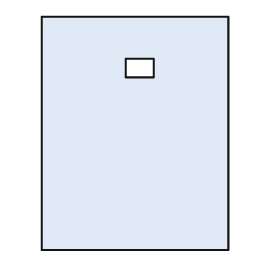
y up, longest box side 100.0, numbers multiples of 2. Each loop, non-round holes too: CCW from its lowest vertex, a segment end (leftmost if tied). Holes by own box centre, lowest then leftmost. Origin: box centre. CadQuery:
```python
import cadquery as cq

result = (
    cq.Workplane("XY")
    .moveTo(-40.0, -50.0)
    .lineTo(40.0, -50.0)
    .lineTo(40.0, 50.0)
    .lineTo(-40.0, 50.0)
    .close()
    .moveTo(-4.0, 24.0)
    .lineTo(8.0, 24.0)
    .lineTo(8.0, 32.0)
    .lineTo(-4.0, 32.0)
    .close()
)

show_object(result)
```